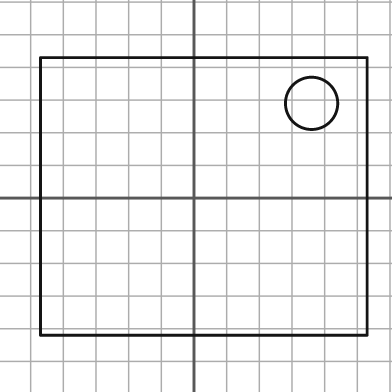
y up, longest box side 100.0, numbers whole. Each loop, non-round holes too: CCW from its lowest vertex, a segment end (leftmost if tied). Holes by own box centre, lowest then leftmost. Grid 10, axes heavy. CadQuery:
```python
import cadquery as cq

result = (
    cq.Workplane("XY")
    .moveTo(-47.0, -42.0)
    .lineTo(53.0, -42.0)
    .lineTo(53.0, 43.0)
    .lineTo(-47.0, 43.0)
    .close()
    .moveTo(36.0, 29.0)
    .circle(8.0)
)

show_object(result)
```